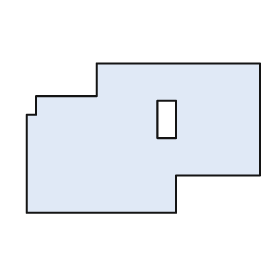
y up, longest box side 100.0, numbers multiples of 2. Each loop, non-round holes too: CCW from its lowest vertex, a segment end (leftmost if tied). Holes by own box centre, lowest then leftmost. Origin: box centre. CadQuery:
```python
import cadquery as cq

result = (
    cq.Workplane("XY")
    .moveTo(-50.0, -32.0)
    .lineTo(14.0, -32.0)
    .lineTo(14.0, -16.0)
    .lineTo(50.0, -16.0)
    .lineTo(50.0, 32.0)
    .lineTo(-20.0, 32.0)
    .lineTo(-20.0, 18.0)
    .lineTo(-46.0, 18.0)
    .lineTo(-46.0, 10.0)
    .lineTo(-50.0, 10.0)
    .close()
    .moveTo(6.0, 0.0)
    .lineTo(14.0, 0.0)
    .lineTo(14.0, 16.0)
    .lineTo(6.0, 16.0)
    .close()
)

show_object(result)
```